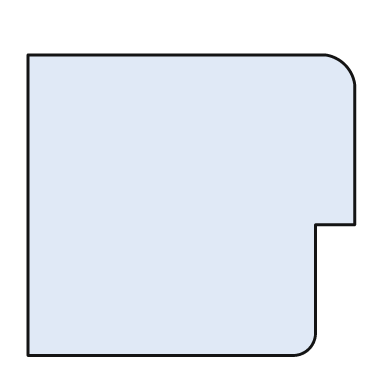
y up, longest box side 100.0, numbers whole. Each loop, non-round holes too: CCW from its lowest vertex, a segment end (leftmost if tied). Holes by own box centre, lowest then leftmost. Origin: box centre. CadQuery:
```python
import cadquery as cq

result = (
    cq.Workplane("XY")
    .moveTo(-50.0, -46.0)
    .lineTo(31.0, -46.0)
    .threePointArc((36.0, -44.0), (38.0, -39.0))
    .lineTo(38.0, -6.0)
    .lineTo(50.0, -6.0)
    .lineTo(50.0, 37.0)
    .threePointArc((47.0, 43.0), (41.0, 46.0))
    .lineTo(-50.0, 46.0)
    .close()
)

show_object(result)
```